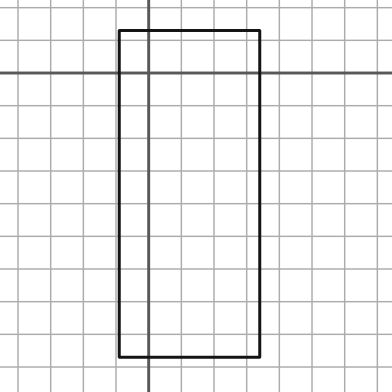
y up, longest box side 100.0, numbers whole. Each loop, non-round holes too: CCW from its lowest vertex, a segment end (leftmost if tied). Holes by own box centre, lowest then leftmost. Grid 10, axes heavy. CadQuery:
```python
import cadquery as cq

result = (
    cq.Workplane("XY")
    .moveTo(-9.0, -87.0)
    .lineTo(34.0, -87.0)
    .lineTo(34.0, 13.0)
    .lineTo(-9.0, 13.0)
    .close()
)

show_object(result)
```